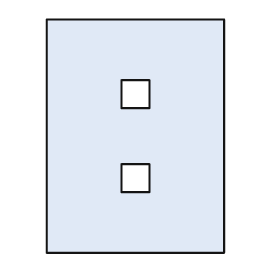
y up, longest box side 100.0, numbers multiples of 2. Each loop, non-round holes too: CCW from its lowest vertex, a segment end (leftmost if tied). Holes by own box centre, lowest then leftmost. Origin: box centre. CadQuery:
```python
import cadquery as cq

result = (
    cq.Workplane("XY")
    .moveTo(-38.0, -50.0)
    .lineTo(38.0, -50.0)
    .lineTo(38.0, 50.0)
    .lineTo(-38.0, 50.0)
    .close()
    .moveTo(-6.0, -24.0)
    .lineTo(6.0, -24.0)
    .lineTo(6.0, -12.0)
    .lineTo(-6.0, -12.0)
    .close()
    .moveTo(-6.0, 12.0)
    .lineTo(6.0, 12.0)
    .lineTo(6.0, 24.0)
    .lineTo(-6.0, 24.0)
    .close()
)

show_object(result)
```